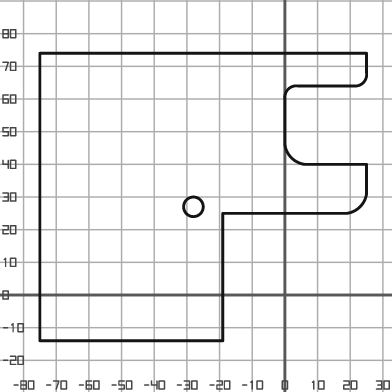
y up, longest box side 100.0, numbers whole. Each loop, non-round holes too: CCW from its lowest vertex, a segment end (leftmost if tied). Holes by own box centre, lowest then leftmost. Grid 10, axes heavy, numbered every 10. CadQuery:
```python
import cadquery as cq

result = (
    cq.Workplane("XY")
    .moveTo(-75.0, -14.0)
    .lineTo(-19.0, -14.0)
    .lineTo(-19.0, 25.0)
    .lineTo(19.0, 25.0)
    .threePointArc((23.0, 27.0), (25.0, 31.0))
    .lineTo(25.0, 40.0)
    .lineTo(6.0, 40.0)
    .threePointArc((2.0, 42.0), (0.0, 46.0))
    .lineTo(0.0, 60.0)
    .threePointArc((1.0, 63.0), (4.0, 64.0))
    .lineTo(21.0, 64.0)
    .threePointArc((24.0, 65.0), (25.0, 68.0))
    .lineTo(25.0, 74.0)
    .lineTo(-75.0, 74.0)
    .close()
    .moveTo(-28.0, 27.0)
    .circle(3.0)
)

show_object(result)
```